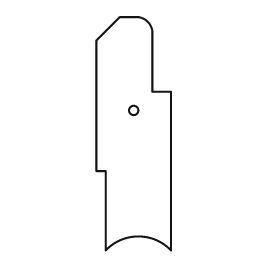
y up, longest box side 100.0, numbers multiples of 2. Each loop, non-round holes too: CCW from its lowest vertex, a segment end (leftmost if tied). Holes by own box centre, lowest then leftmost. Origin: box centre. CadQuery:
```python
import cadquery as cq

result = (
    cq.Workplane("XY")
    .moveTo(-12.0, -50.0)
    .threePointArc((2.0, -44.0), (16.0, -50.0))
    .lineTo(16.0, 18.0)
    .lineTo(8.0, 18.0)
    .lineTo(8.0, 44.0)
    .threePointArc((6.0, 48.0), (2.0, 50.0))
    .lineTo(-6.0, 50.0)
    .lineTo(-16.0, 40.0)
    .lineTo(-16.0, -16.0)
    .lineTo(-12.0, -16.0)
    .close()
    .moveTo(0.0, 10.0)
    .circle(2.0)
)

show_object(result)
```